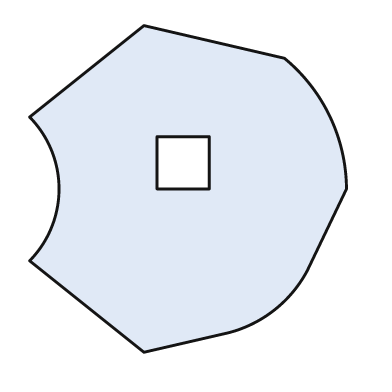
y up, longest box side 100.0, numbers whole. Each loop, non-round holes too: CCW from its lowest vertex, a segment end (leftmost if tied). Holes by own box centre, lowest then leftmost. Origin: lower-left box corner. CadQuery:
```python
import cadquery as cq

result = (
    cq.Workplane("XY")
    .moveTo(35.0, 0.0)
    .lineTo(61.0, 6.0)
    .threePointArc((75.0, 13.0), (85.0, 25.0))
    .lineTo(97.0, 50.0)
    .threePointArc((92.0, 72.0), (78.0, 90.0))
    .lineTo(35.0, 100.0)
    .lineTo(0.0, 72.0)
    .threePointArc((9.0, 50.0), (0.0, 28.0))
    .close()
    .moveTo(39.0, 50.0)
    .lineTo(55.0, 50.0)
    .lineTo(55.0, 66.0)
    .lineTo(39.0, 66.0)
    .close()
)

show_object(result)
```